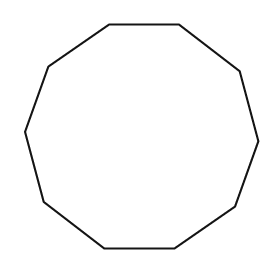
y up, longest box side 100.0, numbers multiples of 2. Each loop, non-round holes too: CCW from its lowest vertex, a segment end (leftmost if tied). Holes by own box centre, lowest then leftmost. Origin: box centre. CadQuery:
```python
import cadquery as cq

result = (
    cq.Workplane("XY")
    .moveTo(-16.0, -48.0)
    .lineTo(14.0, -48.0)
    .lineTo(40.0, -30.0)
    .lineTo(50.0, -2.0)
    .lineTo(42.0, 28.0)
    .lineTo(16.0, 48.0)
    .lineTo(-14.0, 48.0)
    .lineTo(-40.0, 30.0)
    .lineTo(-50.0, 2.0)
    .lineTo(-42.0, -28.0)
    .close()
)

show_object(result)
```